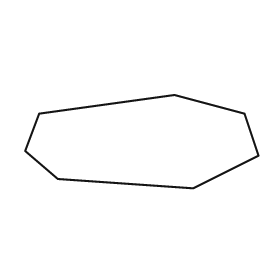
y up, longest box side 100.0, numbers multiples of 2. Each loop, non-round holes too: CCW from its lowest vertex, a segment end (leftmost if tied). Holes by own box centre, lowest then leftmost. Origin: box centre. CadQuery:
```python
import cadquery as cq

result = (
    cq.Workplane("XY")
    .moveTo(22.0, -20.0)
    .lineTo(50.0, -6.0)
    .lineTo(44.0, 12.0)
    .lineTo(14.0, 20.0)
    .lineTo(-44.0, 12.0)
    .lineTo(-50.0, -4.0)
    .lineTo(-36.0, -16.0)
    .close()
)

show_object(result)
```